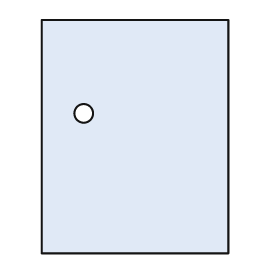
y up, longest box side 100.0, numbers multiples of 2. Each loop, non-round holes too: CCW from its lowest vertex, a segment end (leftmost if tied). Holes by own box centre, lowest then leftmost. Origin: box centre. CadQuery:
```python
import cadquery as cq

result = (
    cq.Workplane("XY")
    .moveTo(-40.0, -50.0)
    .lineTo(40.0, -50.0)
    .lineTo(40.0, 50.0)
    .lineTo(-40.0, 50.0)
    .close()
    .moveTo(-22.0, 10.0)
    .circle(4.0)
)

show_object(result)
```